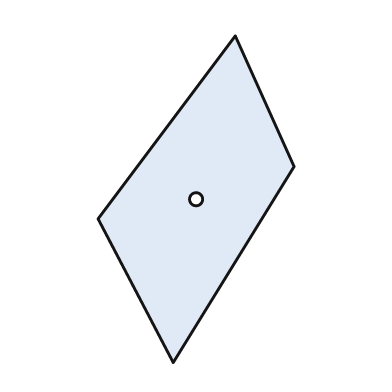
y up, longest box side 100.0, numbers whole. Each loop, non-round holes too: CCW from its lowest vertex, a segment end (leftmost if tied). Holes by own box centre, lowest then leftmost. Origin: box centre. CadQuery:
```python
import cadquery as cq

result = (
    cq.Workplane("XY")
    .moveTo(-7.0, -50.0)
    .lineTo(30.0, 10.0)
    .lineTo(12.0, 50.0)
    .lineTo(-30.0, -6.0)
    .close()
    .moveTo(0.0, 0.0)
    .circle(2.0)
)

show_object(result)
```